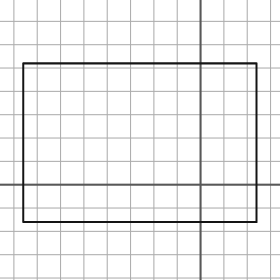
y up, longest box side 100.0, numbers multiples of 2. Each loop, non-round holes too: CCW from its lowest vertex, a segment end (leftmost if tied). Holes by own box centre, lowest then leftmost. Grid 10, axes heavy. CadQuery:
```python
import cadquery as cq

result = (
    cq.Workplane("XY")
    .moveTo(-76.0, -16.0)
    .lineTo(24.0, -16.0)
    .lineTo(24.0, 52.0)
    .lineTo(-76.0, 52.0)
    .close()
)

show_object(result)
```